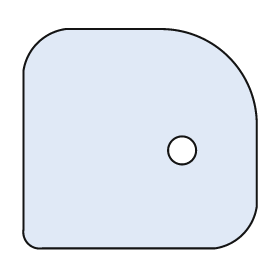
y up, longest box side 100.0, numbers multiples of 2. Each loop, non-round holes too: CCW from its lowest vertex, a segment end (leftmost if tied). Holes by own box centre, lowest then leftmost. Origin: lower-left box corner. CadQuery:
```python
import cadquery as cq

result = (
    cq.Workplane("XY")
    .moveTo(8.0, 0.0)
    .lineTo(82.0, 0.0)
    .threePointArc((94.0, 6.0), (100.0, 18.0))
    .lineTo(100.0, 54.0)
    .threePointArc((88.0, 82.0), (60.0, 94.0))
    .lineTo(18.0, 94.0)
    .threePointArc((6.0, 88.0), (0.0, 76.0))
    .lineTo(0.0, 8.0)
    .threePointArc((2.0, 2.0), (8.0, 0.0))
    .close()
    .moveTo(68.0, 42.0)
    .circle(6.0)
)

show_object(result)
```